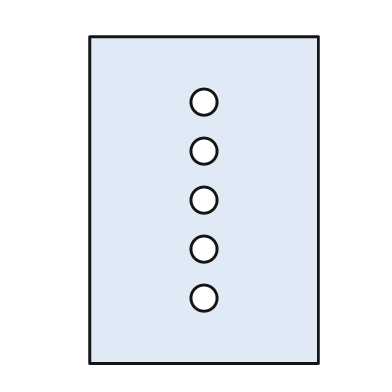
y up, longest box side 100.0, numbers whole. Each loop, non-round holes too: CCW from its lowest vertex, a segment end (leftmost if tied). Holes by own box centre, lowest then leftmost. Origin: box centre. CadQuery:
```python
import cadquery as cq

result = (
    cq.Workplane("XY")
    .moveTo(-35.0, -50.0)
    .lineTo(35.0, -50.0)
    .lineTo(35.0, 50.0)
    .lineTo(-35.0, 50.0)
    .close()
    .moveTo(0.0, -30.0)
    .circle(4.0)
    .moveTo(0.0, -15.0)
    .circle(4.0)
    .moveTo(0.0, 0.0)
    .circle(4.0)
    .moveTo(0.0, 15.0)
    .circle(4.0)
    .moveTo(0.0, 30.0)
    .circle(4.0)
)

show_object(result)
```